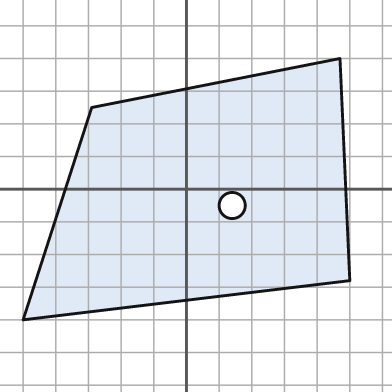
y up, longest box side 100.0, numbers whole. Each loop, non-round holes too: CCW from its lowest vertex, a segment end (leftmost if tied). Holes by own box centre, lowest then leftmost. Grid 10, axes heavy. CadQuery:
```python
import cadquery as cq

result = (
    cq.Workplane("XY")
    .moveTo(-50.0, -40.0)
    .lineTo(50.0, -28.0)
    .lineTo(47.0, 40.0)
    .lineTo(-29.0, 25.0)
    .close()
    .moveTo(14.0, -5.0)
    .circle(4.0)
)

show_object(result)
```